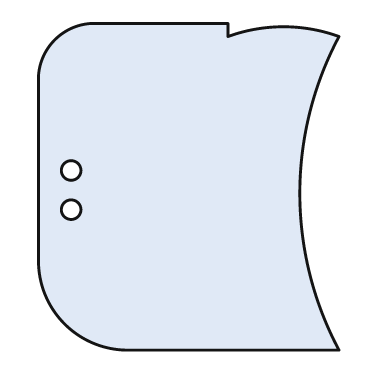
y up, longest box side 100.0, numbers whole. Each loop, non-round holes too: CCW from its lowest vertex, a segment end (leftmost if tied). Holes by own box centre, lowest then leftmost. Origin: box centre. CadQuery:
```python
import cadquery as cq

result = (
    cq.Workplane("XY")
    .moveTo(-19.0, -50.0)
    .lineTo(46.0, -50.0)
    .threePointArc((34.0, -2.0), (46.0, 46.0))
    .threePointArc((29.0, 49.0), (12.0, 46.0))
    .lineTo(12.0, 50.0)
    .lineTo(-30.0, 50.0)
    .threePointArc((-41.0, 45.0), (-46.0, 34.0))
    .lineTo(-46.0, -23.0)
    .threePointArc((-38.0, -42.0), (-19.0, -50.0))
    .close()
    .moveTo(-36.0, -7.0)
    .circle(3.0)
    .moveTo(-36.0, 5.0)
    .circle(3.0)
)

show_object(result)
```